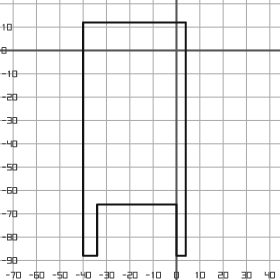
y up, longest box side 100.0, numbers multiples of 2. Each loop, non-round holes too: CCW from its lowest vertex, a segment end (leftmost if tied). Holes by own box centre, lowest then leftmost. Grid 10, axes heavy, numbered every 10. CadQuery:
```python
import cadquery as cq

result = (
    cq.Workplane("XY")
    .moveTo(-40.0, -88.0)
    .lineTo(-34.0, -88.0)
    .lineTo(-34.0, -66.0)
    .lineTo(0.0, -66.0)
    .lineTo(0.0, -88.0)
    .lineTo(4.0, -88.0)
    .lineTo(4.0, 12.0)
    .lineTo(-40.0, 12.0)
    .close()
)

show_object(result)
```